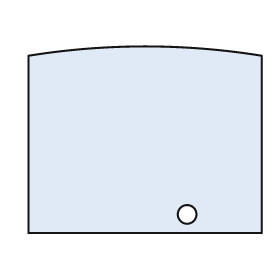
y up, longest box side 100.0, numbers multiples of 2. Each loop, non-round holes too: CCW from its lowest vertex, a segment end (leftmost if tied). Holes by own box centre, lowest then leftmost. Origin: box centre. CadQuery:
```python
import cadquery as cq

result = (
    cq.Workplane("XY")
    .moveTo(-50.0, -40.0)
    .lineTo(50.0, -40.0)
    .lineTo(50.0, 36.0)
    .threePointArc((0.0, 40.0), (-50.0, 36.0))
    .close()
    .moveTo(18.0, -32.0)
    .circle(4.0)
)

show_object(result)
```